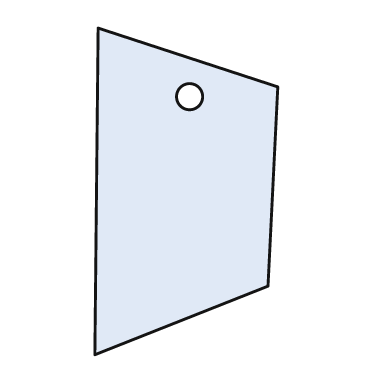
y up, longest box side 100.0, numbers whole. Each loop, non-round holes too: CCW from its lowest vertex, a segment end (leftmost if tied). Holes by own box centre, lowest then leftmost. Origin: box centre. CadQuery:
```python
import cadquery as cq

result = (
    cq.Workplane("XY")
    .moveTo(-28.0, -50.0)
    .lineTo(25.0, -29.0)
    .lineTo(28.0, 32.0)
    .lineTo(-27.0, 50.0)
    .close()
    .moveTo(1.0, 29.0)
    .circle(4.0)
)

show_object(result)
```